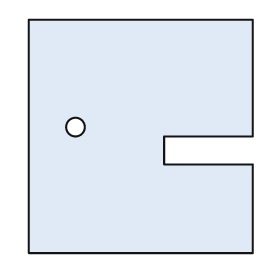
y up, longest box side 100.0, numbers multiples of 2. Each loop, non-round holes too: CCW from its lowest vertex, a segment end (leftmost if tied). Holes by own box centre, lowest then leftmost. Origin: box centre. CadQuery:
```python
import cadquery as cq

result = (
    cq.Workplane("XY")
    .moveTo(-48.0, -50.0)
    .lineTo(48.0, -50.0)
    .lineTo(48.0, -12.0)
    .lineTo(10.0, -12.0)
    .lineTo(10.0, 0.0)
    .lineTo(48.0, 0.0)
    .lineTo(48.0, 50.0)
    .lineTo(-48.0, 50.0)
    .close()
    .moveTo(-28.0, 4.0)
    .circle(4.0)
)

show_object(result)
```